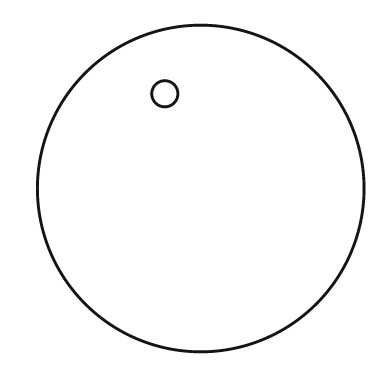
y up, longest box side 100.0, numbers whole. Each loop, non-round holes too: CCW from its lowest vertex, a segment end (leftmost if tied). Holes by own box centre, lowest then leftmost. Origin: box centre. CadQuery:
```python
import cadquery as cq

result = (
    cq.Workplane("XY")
    .moveTo(0.0, 0.0)
    .circle(50.0)
    .moveTo(-11.0, 29.0)
    .circle(4.0)
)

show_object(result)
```